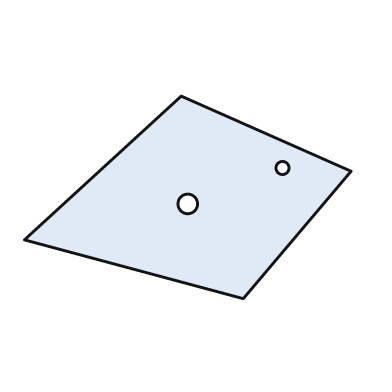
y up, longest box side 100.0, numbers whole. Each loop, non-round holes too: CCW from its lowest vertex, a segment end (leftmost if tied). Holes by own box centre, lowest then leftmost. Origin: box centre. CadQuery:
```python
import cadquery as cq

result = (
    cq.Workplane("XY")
    .moveTo(17.0, -31.0)
    .lineTo(50.0, 8.0)
    .lineTo(-2.0, 31.0)
    .lineTo(-50.0, -13.0)
    .close()
    .moveTo(0.0, -2.0)
    .circle(3.0)
    .moveTo(29.0, 9.0)
    .circle(2.0)
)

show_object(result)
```